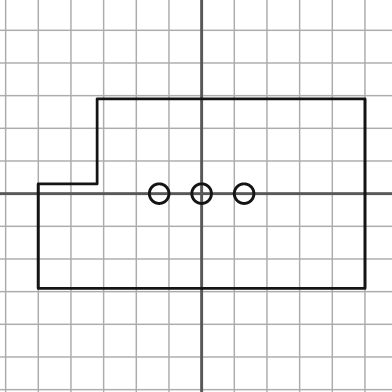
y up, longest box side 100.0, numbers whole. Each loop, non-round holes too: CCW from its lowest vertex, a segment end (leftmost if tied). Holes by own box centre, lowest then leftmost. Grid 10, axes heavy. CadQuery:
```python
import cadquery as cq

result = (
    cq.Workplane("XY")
    .moveTo(-50.0, -29.0)
    .lineTo(50.0, -29.0)
    .lineTo(50.0, 29.0)
    .lineTo(-32.0, 29.0)
    .lineTo(-32.0, 3.0)
    .lineTo(-50.0, 3.0)
    .close()
    .moveTo(-13.0, 0.0)
    .circle(3.0)
    .moveTo(0.0, 0.0)
    .circle(3.0)
    .moveTo(13.0, 0.0)
    .circle(3.0)
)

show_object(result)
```